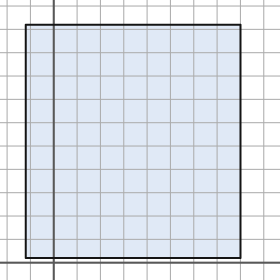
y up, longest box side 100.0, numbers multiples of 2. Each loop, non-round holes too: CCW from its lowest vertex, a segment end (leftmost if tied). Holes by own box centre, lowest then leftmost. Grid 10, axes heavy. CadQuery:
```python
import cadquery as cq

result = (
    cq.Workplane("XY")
    .moveTo(-12.0, 2.0)
    .lineTo(80.0, 2.0)
    .lineTo(80.0, 102.0)
    .lineTo(-12.0, 102.0)
    .close()
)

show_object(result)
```